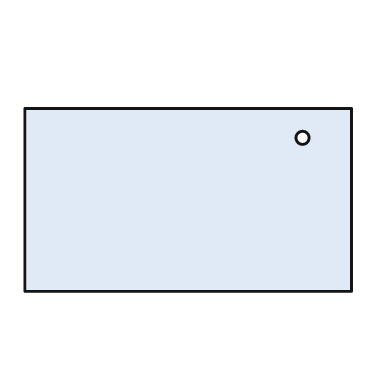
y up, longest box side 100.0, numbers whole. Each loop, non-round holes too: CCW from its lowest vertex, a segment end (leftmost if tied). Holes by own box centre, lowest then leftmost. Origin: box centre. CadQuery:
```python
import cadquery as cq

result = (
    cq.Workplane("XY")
    .moveTo(-50.0, -28.0)
    .lineTo(50.0, -28.0)
    .lineTo(50.0, 28.0)
    .lineTo(-50.0, 28.0)
    .close()
    .moveTo(35.0, 19.0)
    .circle(2.0)
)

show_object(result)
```